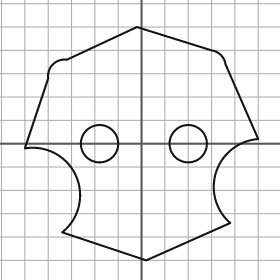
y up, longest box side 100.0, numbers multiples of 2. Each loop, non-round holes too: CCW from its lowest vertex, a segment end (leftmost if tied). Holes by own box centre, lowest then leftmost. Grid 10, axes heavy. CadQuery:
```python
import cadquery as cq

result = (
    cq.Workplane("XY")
    .moveTo(2.0, -50.0)
    .lineTo(38.0, -34.0)
    .threePointArc((32.0, -12.0), (50.0, 2.0))
    .lineTo(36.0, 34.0)
    .threePointArc((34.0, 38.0), (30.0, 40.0))
    .lineTo(-2.0, 50.0)
    .lineTo(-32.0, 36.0)
    .threePointArc((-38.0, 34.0), (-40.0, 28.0))
    .lineTo(-50.0, -2.0)
    .threePointArc((-28.0, -14.0), (-34.0, -38.0))
    .close()
    .moveTo(-18.0, 0.0)
    .circle(8.0)
    .moveTo(20.0, 0.0)
    .circle(8.0)
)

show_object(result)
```